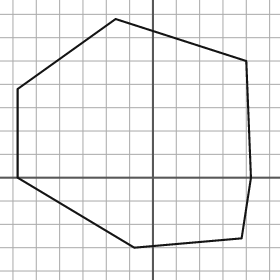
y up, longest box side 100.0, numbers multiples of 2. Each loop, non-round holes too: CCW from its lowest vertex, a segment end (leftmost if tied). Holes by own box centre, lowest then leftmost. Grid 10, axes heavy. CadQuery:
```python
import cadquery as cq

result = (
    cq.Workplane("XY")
    .moveTo(-8.0, -30.0)
    .lineTo(38.0, -26.0)
    .lineTo(42.0, 0.0)
    .lineTo(40.0, 50.0)
    .lineTo(-16.0, 68.0)
    .lineTo(-58.0, 38.0)
    .lineTo(-58.0, 0.0)
    .close()
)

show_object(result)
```